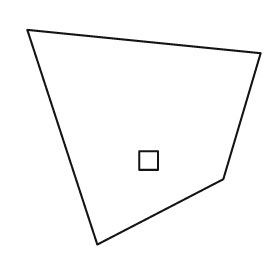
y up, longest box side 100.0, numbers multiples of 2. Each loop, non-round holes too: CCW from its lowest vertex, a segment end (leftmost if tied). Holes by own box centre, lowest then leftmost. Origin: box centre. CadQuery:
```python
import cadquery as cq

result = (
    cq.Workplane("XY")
    .moveTo(-20.0, -46.0)
    .lineTo(34.0, -18.0)
    .lineTo(50.0, 36.0)
    .lineTo(-50.0, 46.0)
    .close()
    .moveTo(-2.0, -14.0)
    .lineTo(6.0, -14.0)
    .lineTo(6.0, -6.0)
    .lineTo(-2.0, -6.0)
    .close()
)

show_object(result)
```